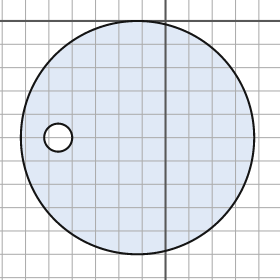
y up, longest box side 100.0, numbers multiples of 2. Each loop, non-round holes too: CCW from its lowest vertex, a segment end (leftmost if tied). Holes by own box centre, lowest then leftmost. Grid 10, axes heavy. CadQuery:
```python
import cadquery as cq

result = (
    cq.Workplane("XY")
    .moveTo(-12.0, -50.0)
    .circle(50.0)
    .moveTo(-46.0, -50.0)
    .circle(6.0)
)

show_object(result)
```